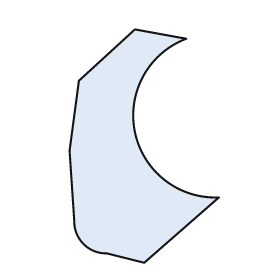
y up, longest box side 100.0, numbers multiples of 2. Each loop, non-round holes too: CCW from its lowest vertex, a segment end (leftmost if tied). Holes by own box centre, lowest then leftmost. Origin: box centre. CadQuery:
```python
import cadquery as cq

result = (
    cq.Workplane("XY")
    .moveTo(0.0, -50.0)
    .lineTo(32.0, -22.0)
    .threePointArc((-4.0, 6.0), (18.0, 46.0))
    .lineTo(-4.0, 50.0)
    .lineTo(-28.0, 28.0)
    .lineTo(-32.0, -2.0)
    .lineTo(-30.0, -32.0)
    .threePointArc((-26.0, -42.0), (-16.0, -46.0))
    .close()
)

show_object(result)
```